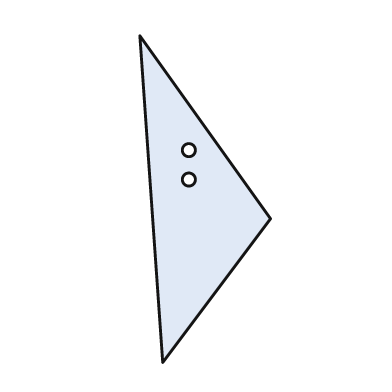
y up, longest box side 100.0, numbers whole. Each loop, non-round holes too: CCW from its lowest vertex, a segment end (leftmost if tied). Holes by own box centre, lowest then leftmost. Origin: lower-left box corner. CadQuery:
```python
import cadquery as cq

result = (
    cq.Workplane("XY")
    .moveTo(7.0, 0.0)
    .lineTo(40.0, 44.0)
    .lineTo(0.0, 100.0)
    .close()
    .moveTo(15.0, 56.0)
    .circle(2.0)
    .moveTo(15.0, 65.0)
    .circle(2.0)
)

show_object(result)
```